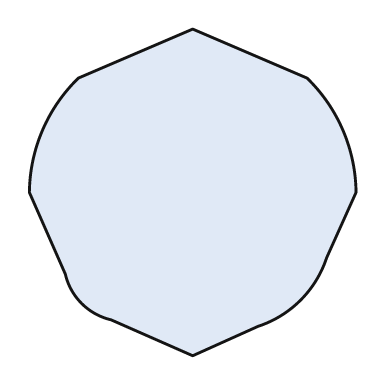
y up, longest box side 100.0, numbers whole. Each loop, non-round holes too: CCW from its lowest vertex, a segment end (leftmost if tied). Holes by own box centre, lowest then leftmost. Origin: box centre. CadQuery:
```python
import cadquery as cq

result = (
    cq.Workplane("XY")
    .moveTo(0.0, -50.0)
    .lineTo(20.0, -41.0)
    .threePointArc((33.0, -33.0), (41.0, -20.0))
    .lineTo(50.0, 0.0)
    .threePointArc((46.0, 19.0), (35.0, 35.0))
    .lineTo(0.0, 50.0)
    .lineTo(-35.0, 35.0)
    .threePointArc((-46.0, 19.0), (-50.0, 0.0))
    .lineTo(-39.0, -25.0)
    .threePointArc((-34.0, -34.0), (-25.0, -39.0))
    .close()
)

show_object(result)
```